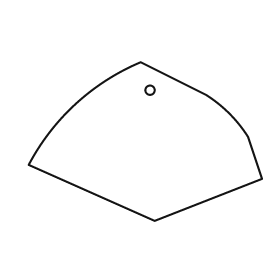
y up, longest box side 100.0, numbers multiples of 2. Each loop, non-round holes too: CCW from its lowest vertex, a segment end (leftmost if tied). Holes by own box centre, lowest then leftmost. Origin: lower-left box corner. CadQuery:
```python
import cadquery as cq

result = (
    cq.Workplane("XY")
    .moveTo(54.0, 0.0)
    .lineTo(100.0, 18.0)
    .lineTo(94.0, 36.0)
    .threePointArc((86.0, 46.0), (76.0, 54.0))
    .lineTo(48.0, 68.0)
    .threePointArc((20.0, 50.0), (0.0, 24.0))
    .close()
    .moveTo(52.0, 56.0)
    .circle(2.0)
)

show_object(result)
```